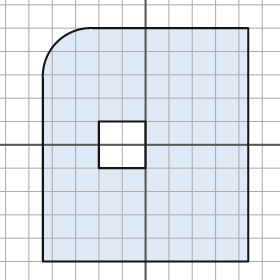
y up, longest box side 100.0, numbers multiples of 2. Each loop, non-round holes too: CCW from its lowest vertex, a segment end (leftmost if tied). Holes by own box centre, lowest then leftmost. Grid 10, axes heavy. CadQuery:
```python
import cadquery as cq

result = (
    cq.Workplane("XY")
    .moveTo(-44.0, -50.0)
    .lineTo(44.0, -50.0)
    .lineTo(44.0, 50.0)
    .lineTo(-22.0, 50.0)
    .threePointArc((-38.0, 44.0), (-44.0, 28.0))
    .close()
    .moveTo(-20.0, -10.0)
    .lineTo(0.0, -10.0)
    .lineTo(0.0, 10.0)
    .lineTo(-20.0, 10.0)
    .close()
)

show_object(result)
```